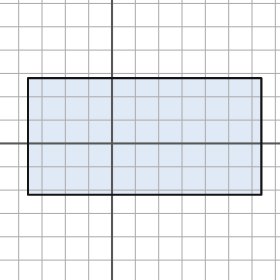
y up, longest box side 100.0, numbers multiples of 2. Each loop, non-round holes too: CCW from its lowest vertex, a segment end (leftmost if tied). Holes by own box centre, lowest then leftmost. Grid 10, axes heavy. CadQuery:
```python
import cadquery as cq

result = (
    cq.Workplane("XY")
    .moveTo(-36.0, -22.0)
    .lineTo(64.0, -22.0)
    .lineTo(64.0, 28.0)
    .lineTo(-36.0, 28.0)
    .close()
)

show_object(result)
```